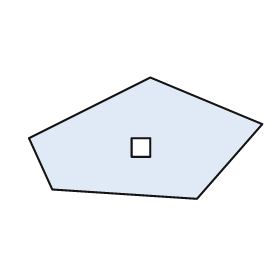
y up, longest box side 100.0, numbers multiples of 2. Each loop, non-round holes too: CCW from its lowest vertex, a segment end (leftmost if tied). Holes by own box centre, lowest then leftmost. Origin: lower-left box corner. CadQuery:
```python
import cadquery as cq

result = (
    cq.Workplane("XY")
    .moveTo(72.0, 0.0)
    .lineTo(100.0, 32.0)
    .lineTo(52.0, 52.0)
    .lineTo(0.0, 26.0)
    .lineTo(10.0, 4.0)
    .close()
    .moveTo(44.0, 18.0)
    .lineTo(52.0, 18.0)
    .lineTo(52.0, 26.0)
    .lineTo(44.0, 26.0)
    .close()
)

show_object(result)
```